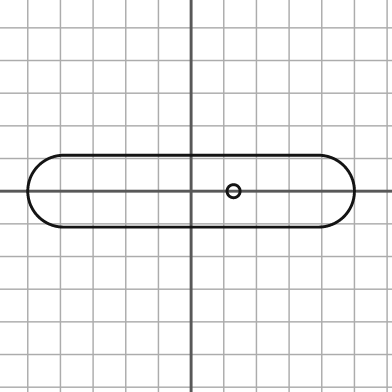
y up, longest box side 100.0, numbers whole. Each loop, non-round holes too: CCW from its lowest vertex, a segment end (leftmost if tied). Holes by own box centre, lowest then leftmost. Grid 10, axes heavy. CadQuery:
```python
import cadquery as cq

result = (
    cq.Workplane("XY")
    .moveTo(-39.0, -11.0)
    .lineTo(39.0, -11.0)
    .threePointArc((50.0, 0.0), (39.0, 11.0))
    .lineTo(-39.0, 11.0)
    .threePointArc((-50.0, 0.0), (-39.0, -11.0))
    .close()
    .moveTo(13.0, 0.0)
    .circle(2.0)
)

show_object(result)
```